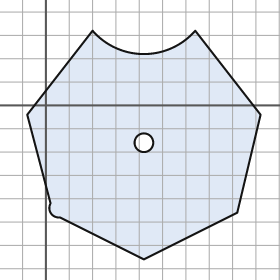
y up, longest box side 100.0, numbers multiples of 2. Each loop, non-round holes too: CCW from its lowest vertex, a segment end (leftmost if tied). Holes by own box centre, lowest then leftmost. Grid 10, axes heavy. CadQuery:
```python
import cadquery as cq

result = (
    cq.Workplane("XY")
    .moveTo(42.0, -66.0)
    .lineTo(82.0, -46.0)
    .lineTo(92.0, -4.0)
    .lineTo(64.0, 32.0)
    .threePointArc((42.0, 22.0), (20.0, 32.0))
    .lineTo(-8.0, -4.0)
    .lineTo(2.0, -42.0)
    .threePointArc((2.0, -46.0), (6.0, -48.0))
    .close()
    .moveTo(42.0, -16.0)
    .circle(4.0)
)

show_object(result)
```